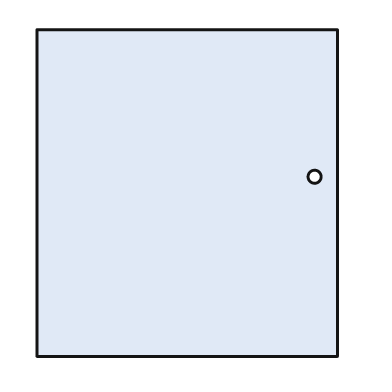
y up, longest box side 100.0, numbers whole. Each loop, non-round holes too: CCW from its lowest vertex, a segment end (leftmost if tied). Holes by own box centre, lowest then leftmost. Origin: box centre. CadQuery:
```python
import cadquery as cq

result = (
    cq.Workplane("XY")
    .moveTo(-46.0, -50.0)
    .lineTo(46.0, -50.0)
    .lineTo(46.0, 50.0)
    .lineTo(-46.0, 50.0)
    .close()
    .moveTo(39.0, 5.0)
    .circle(2.0)
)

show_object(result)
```